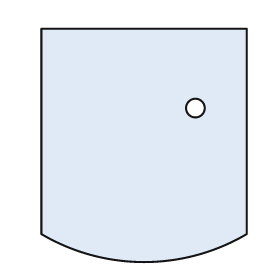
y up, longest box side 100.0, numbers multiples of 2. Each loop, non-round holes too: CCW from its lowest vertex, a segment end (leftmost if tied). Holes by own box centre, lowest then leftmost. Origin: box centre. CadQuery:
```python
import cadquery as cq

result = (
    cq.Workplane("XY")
    .moveTo(-44.0, -38.0)
    .threePointArc((0.0, -50.0), (44.0, -38.0))
    .lineTo(44.0, 50.0)
    .lineTo(-44.0, 50.0)
    .close()
    .moveTo(22.0, 16.0)
    .circle(4.0)
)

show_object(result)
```